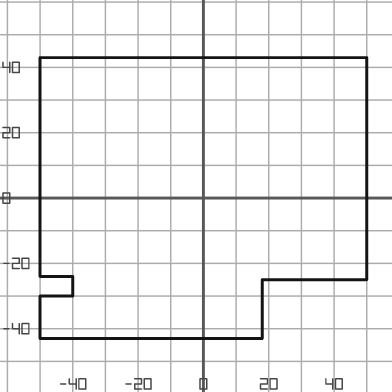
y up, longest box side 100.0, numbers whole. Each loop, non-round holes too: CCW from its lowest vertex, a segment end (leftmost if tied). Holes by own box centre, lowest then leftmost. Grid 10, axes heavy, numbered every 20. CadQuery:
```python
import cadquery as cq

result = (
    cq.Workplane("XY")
    .moveTo(-50.0, -43.0)
    .lineTo(18.0, -43.0)
    .lineTo(18.0, -25.0)
    .lineTo(50.0, -25.0)
    .lineTo(50.0, 43.0)
    .lineTo(-50.0, 43.0)
    .lineTo(-50.0, -24.0)
    .lineTo(-40.0, -24.0)
    .lineTo(-40.0, -30.0)
    .lineTo(-50.0, -30.0)
    .close()
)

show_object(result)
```